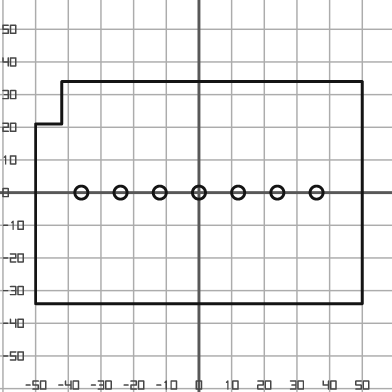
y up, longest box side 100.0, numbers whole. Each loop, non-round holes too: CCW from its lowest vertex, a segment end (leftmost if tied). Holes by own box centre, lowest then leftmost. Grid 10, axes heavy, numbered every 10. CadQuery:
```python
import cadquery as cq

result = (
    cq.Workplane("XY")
    .moveTo(-50.0, -34.0)
    .lineTo(50.0, -34.0)
    .lineTo(50.0, 34.0)
    .lineTo(-42.0, 34.0)
    .lineTo(-42.0, 21.0)
    .lineTo(-50.0, 21.0)
    .close()
    .moveTo(-36.0, 0.0)
    .circle(2.0)
    .moveTo(-24.0, 0.0)
    .circle(2.0)
    .moveTo(-12.0, 0.0)
    .circle(2.0)
    .moveTo(0.0, 0.0)
    .circle(2.0)
    .moveTo(12.0, 0.0)
    .circle(2.0)
    .moveTo(24.0, 0.0)
    .circle(2.0)
    .moveTo(36.0, 0.0)
    .circle(2.0)
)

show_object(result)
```